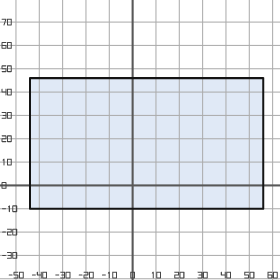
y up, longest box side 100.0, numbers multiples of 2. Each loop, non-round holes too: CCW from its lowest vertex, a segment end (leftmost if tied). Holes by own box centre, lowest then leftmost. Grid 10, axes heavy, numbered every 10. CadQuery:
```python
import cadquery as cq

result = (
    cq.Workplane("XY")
    .moveTo(-44.0, -10.0)
    .lineTo(56.0, -10.0)
    .lineTo(56.0, 46.0)
    .lineTo(-44.0, 46.0)
    .close()
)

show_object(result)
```